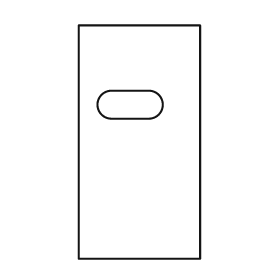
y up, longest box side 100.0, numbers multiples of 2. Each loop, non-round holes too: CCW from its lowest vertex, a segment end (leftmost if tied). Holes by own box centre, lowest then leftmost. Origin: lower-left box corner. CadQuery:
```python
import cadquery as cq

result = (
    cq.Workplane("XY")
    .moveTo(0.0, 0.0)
    .lineTo(52.0, 0.0)
    .lineTo(52.0, 100.0)
    .lineTo(0.0, 100.0)
    .close()
    .moveTo(14.0, 60.0)
    .lineTo(30.0, 60.0)
    .threePointArc((36.0, 66.0), (30.0, 72.0))
    .lineTo(14.0, 72.0)
    .threePointArc((8.0, 66.0), (14.0, 60.0))
    .close()
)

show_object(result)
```